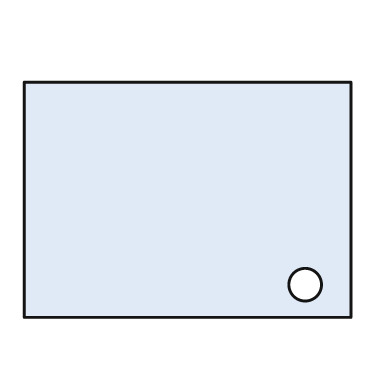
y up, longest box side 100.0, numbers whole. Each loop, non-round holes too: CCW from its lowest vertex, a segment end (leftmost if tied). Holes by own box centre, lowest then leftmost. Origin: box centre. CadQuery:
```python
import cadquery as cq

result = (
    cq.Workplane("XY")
    .moveTo(-50.0, -36.0)
    .lineTo(50.0, -36.0)
    .lineTo(50.0, 36.0)
    .lineTo(-50.0, 36.0)
    .close()
    .moveTo(36.0, -26.0)
    .circle(5.0)
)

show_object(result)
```